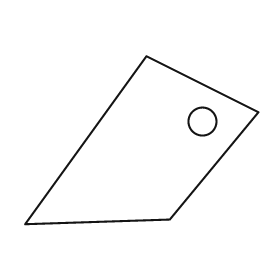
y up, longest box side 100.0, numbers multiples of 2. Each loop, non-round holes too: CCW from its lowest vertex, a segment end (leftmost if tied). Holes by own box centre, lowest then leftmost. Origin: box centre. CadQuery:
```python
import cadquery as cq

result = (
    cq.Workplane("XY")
    .moveTo(-50.0, -36.0)
    .lineTo(12.0, -34.0)
    .lineTo(50.0, 12.0)
    .lineTo(2.0, 36.0)
    .close()
    .moveTo(26.0, 8.0)
    .circle(6.0)
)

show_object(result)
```